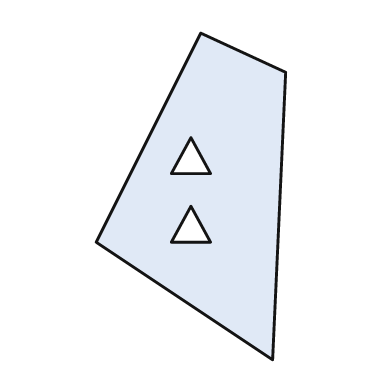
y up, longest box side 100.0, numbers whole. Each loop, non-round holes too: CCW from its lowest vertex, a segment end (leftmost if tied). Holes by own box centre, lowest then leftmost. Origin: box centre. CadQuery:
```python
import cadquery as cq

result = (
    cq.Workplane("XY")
    .moveTo(25.0, -50.0)
    .lineTo(29.0, 38.0)
    .lineTo(3.0, 50.0)
    .lineTo(-29.0, -14.0)
    .close()
    .moveTo(-6.0, -14.0)
    .lineTo(6.0, -14.0)
    .lineTo(0.0, -3.0)
    .close()
    .moveTo(-6.0, 7.0)
    .lineTo(6.0, 7.0)
    .lineTo(0.0, 18.0)
    .close()
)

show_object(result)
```